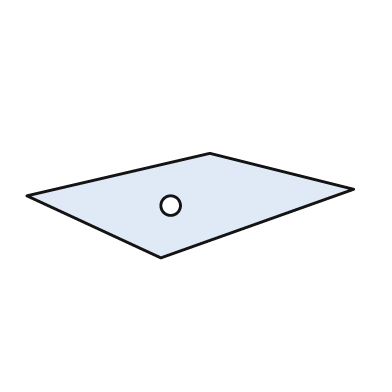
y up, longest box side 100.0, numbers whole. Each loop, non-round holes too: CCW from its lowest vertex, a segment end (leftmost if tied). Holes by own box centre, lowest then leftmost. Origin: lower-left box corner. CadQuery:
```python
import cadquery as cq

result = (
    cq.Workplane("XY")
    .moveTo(41.0, 0.0)
    .lineTo(100.0, 21.0)
    .lineTo(56.0, 32.0)
    .lineTo(0.0, 19.0)
    .close()
    .moveTo(44.0, 16.0)
    .circle(3.0)
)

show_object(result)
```